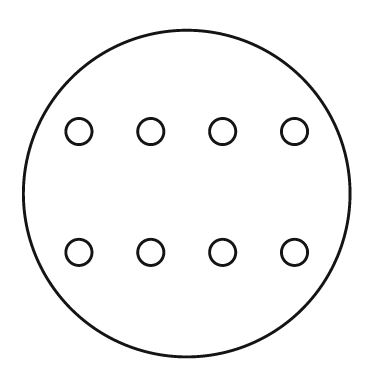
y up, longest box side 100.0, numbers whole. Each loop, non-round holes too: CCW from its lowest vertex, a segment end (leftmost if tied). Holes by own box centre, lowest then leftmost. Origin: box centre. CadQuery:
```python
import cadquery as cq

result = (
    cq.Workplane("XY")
    .moveTo(0.0, 0.0)
    .circle(50.0)
    .moveTo(-33.0, -18.0)
    .circle(4.0)
    .moveTo(-11.0, -18.0)
    .circle(4.0)
    .moveTo(11.0, -18.0)
    .circle(4.0)
    .moveTo(33.0, -18.0)
    .circle(4.0)
    .moveTo(-33.0, 19.0)
    .circle(4.0)
    .moveTo(-11.0, 19.0)
    .circle(4.0)
    .moveTo(11.0, 19.0)
    .circle(4.0)
    .moveTo(33.0, 19.0)
    .circle(4.0)
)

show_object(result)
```